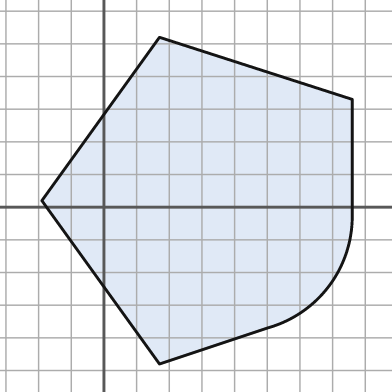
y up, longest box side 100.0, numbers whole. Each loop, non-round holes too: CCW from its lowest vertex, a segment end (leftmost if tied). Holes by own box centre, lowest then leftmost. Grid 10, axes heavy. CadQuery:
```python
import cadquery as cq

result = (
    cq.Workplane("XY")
    .moveTo(17.0, -48.0)
    .lineTo(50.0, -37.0)
    .threePointArc((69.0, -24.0), (76.0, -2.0))
    .lineTo(76.0, 33.0)
    .lineTo(17.0, 52.0)
    .lineTo(-19.0, 2.0)
    .close()
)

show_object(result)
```